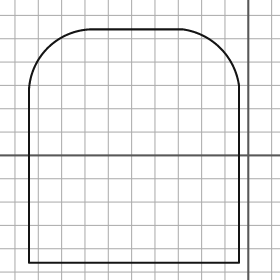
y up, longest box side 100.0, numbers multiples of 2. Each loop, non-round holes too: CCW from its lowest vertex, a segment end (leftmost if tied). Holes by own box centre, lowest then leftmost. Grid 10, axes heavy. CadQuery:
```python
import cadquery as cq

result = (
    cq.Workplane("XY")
    .moveTo(-94.0, -46.0)
    .lineTo(-4.0, -46.0)
    .lineTo(-4.0, 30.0)
    .threePointArc((-12.0, 46.0), (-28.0, 54.0))
    .lineTo(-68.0, 54.0)
    .threePointArc((-86.0, 46.0), (-94.0, 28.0))
    .close()
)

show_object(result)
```